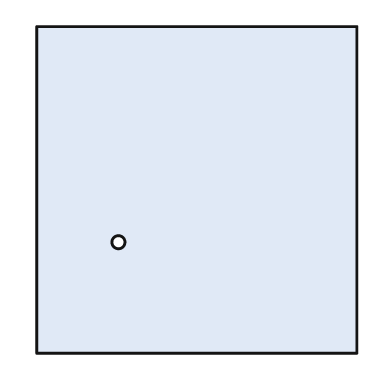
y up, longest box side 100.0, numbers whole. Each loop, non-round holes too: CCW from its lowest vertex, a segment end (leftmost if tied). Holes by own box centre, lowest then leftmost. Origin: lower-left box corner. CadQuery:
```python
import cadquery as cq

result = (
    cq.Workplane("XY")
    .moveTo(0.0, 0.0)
    .lineTo(98.0, 0.0)
    .lineTo(98.0, 100.0)
    .lineTo(0.0, 100.0)
    .close()
    .moveTo(25.0, 34.0)
    .circle(2.0)
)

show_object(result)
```